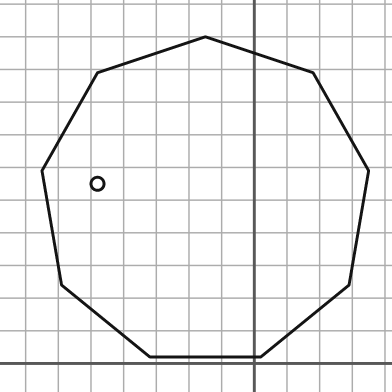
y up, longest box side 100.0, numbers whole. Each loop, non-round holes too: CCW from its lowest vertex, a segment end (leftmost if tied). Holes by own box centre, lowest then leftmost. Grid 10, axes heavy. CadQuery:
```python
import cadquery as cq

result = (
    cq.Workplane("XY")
    .moveTo(-32.0, 2.0)
    .lineTo(2.0, 2.0)
    .lineTo(29.0, 24.0)
    .lineTo(35.0, 59.0)
    .lineTo(18.0, 89.0)
    .lineTo(-15.0, 100.0)
    .lineTo(-48.0, 89.0)
    .lineTo(-65.0, 59.0)
    .lineTo(-59.0, 24.0)
    .close()
    .moveTo(-48.0, 55.0)
    .circle(2.0)
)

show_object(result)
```